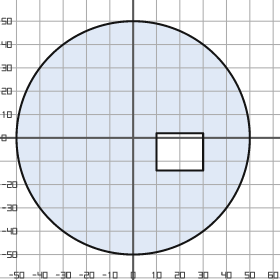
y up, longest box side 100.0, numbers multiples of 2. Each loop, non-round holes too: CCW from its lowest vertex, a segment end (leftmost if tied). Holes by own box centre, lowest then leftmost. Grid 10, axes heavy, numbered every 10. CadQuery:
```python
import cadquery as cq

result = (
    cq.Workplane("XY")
    .moveTo(0.0, 0.0)
    .circle(50.0)
    .moveTo(10.0, -14.0)
    .lineTo(30.0, -14.0)
    .lineTo(30.0, 2.0)
    .lineTo(10.0, 2.0)
    .close()
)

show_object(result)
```